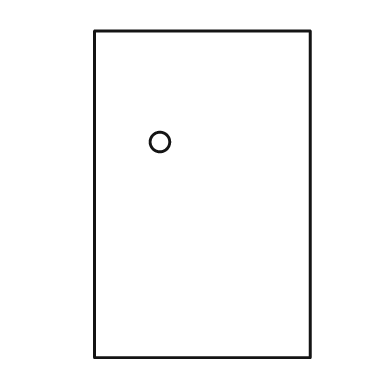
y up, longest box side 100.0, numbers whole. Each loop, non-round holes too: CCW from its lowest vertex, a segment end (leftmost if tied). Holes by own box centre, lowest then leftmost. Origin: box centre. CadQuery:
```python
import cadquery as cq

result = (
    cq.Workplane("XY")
    .moveTo(-33.0, -50.0)
    .lineTo(33.0, -50.0)
    .lineTo(33.0, 50.0)
    .lineTo(-33.0, 50.0)
    .close()
    .moveTo(-13.0, 16.0)
    .circle(3.0)
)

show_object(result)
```